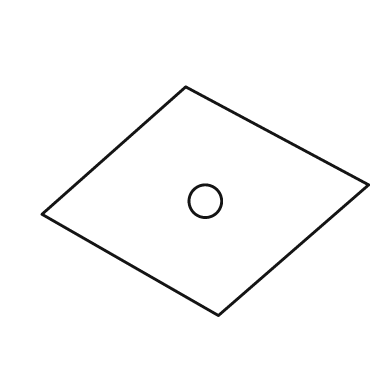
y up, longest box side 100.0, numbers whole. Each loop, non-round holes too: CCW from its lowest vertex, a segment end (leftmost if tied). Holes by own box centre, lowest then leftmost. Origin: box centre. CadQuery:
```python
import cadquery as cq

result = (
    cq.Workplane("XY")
    .moveTo(4.0, -35.0)
    .lineTo(50.0, 5.0)
    .lineTo(-6.0, 35.0)
    .lineTo(-50.0, -4.0)
    .close()
    .moveTo(0.0, 0.0)
    .circle(5.0)
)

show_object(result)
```